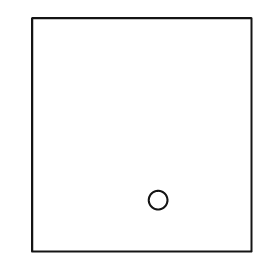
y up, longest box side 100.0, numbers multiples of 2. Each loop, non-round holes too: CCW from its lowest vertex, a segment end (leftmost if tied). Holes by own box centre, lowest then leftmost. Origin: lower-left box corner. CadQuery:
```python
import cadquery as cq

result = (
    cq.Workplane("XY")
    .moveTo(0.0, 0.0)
    .lineTo(94.0, 0.0)
    .lineTo(94.0, 100.0)
    .lineTo(0.0, 100.0)
    .close()
    .moveTo(54.0, 22.0)
    .circle(4.0)
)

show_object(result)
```